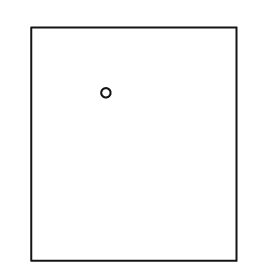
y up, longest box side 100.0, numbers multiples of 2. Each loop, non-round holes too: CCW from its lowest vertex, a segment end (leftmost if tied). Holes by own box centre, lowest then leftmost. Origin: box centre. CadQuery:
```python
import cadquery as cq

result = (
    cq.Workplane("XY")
    .moveTo(-44.0, -50.0)
    .lineTo(44.0, -50.0)
    .lineTo(44.0, 50.0)
    .lineTo(-44.0, 50.0)
    .close()
    .moveTo(-12.0, 22.0)
    .circle(2.0)
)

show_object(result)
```